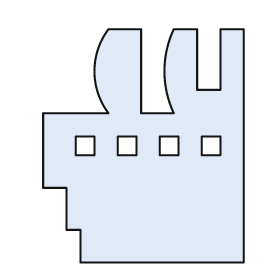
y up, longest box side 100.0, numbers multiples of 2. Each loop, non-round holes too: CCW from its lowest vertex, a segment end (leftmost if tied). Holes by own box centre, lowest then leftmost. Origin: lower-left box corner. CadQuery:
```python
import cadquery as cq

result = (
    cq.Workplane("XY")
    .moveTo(16.0, 0.0)
    .lineTo(86.0, 0.0)
    .lineTo(86.0, 100.0)
    .lineTo(76.0, 100.0)
    .lineTo(76.0, 74.0)
    .lineTo(66.0, 74.0)
    .lineTo(66.0, 100.0)
    .lineTo(56.0, 100.0)
    .threePointArc((52.0, 82.0), (56.0, 64.0))
    .lineTo(42.0, 64.0)
    .lineTo(42.0, 100.0)
    .lineTo(28.0, 100.0)
    .threePointArc((22.0, 82.0), (28.0, 64.0))
    .lineTo(0.0, 64.0)
    .lineTo(0.0, 32.0)
    .lineTo(10.0, 32.0)
    .lineTo(10.0, 14.0)
    .lineTo(16.0, 14.0)
    .close()
    .moveTo(14.0, 46.0)
    .lineTo(22.0, 46.0)
    .lineTo(22.0, 54.0)
    .lineTo(14.0, 54.0)
    .close()
    .moveTo(32.0, 46.0)
    .lineTo(40.0, 46.0)
    .lineTo(40.0, 54.0)
    .lineTo(32.0, 54.0)
    .close()
    .moveTo(50.0, 46.0)
    .lineTo(58.0, 46.0)
    .lineTo(58.0, 54.0)
    .lineTo(50.0, 54.0)
    .close()
    .moveTo(68.0, 46.0)
    .lineTo(76.0, 46.0)
    .lineTo(76.0, 54.0)
    .lineTo(68.0, 54.0)
    .close()
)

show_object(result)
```